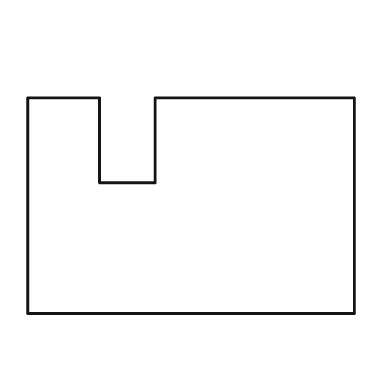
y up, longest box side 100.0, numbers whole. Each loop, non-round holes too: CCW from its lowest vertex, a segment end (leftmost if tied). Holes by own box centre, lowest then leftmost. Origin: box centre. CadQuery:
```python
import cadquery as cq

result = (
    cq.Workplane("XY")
    .moveTo(-50.0, -33.0)
    .lineTo(50.0, -33.0)
    .lineTo(50.0, 33.0)
    .lineTo(-11.0, 33.0)
    .lineTo(-11.0, 7.0)
    .lineTo(-28.0, 7.0)
    .lineTo(-28.0, 33.0)
    .lineTo(-50.0, 33.0)
    .close()
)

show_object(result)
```